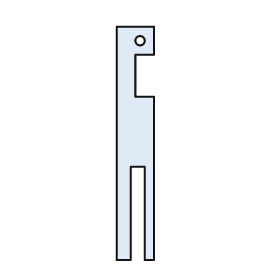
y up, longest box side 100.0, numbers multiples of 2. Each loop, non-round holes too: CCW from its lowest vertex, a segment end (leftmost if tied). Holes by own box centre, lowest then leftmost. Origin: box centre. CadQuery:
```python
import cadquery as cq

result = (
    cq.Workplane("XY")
    .moveTo(-8.0, -50.0)
    .lineTo(-2.0, -50.0)
    .lineTo(-2.0, -10.0)
    .lineTo(4.0, -10.0)
    .lineTo(4.0, -50.0)
    .lineTo(8.0, -50.0)
    .lineTo(8.0, 20.0)
    .lineTo(0.0, 20.0)
    .lineTo(0.0, 38.0)
    .lineTo(8.0, 38.0)
    .lineTo(8.0, 50.0)
    .lineTo(-8.0, 50.0)
    .close()
    .moveTo(2.0, 44.0)
    .circle(2.0)
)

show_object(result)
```